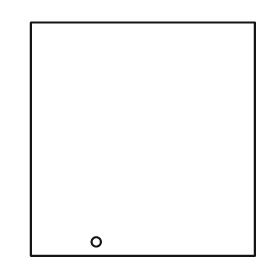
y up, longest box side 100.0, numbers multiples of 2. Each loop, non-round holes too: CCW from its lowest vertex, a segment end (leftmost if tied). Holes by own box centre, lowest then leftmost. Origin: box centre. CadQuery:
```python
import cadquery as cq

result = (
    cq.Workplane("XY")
    .moveTo(-48.0, -50.0)
    .lineTo(48.0, -50.0)
    .lineTo(48.0, 50.0)
    .lineTo(-48.0, 50.0)
    .close()
    .moveTo(-20.0, -44.0)
    .circle(2.0)
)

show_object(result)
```